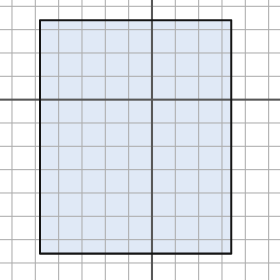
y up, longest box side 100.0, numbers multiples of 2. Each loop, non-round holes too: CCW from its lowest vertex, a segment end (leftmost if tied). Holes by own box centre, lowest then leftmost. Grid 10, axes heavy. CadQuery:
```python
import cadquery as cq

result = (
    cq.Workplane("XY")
    .moveTo(-48.0, -66.0)
    .lineTo(34.0, -66.0)
    .lineTo(34.0, 34.0)
    .lineTo(-48.0, 34.0)
    .close()
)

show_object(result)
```